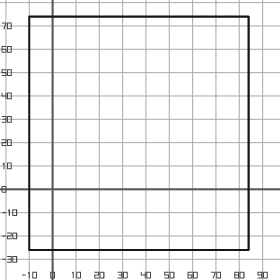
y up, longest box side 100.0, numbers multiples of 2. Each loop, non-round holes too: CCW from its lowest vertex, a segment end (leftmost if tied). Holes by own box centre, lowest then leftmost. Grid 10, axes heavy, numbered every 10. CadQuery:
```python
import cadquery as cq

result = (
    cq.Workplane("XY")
    .moveTo(-10.0, -26.0)
    .lineTo(84.0, -26.0)
    .lineTo(84.0, 74.0)
    .lineTo(-10.0, 74.0)
    .close()
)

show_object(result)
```